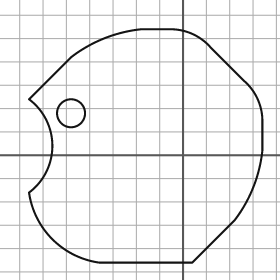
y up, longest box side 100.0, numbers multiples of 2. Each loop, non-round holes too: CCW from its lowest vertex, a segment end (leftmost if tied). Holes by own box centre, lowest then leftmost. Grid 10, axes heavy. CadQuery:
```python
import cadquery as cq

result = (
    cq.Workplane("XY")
    .moveTo(-36.0, -46.0)
    .lineTo(4.0, -46.0)
    .lineTo(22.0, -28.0)
    .threePointArc((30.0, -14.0), (34.0, 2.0))
    .lineTo(34.0, 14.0)
    .threePointArc((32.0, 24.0), (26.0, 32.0))
    .lineTo(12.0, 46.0)
    .threePointArc((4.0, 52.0), (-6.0, 54.0))
    .lineTo(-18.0, 54.0)
    .threePointArc((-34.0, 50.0), (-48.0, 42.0))
    .lineTo(-66.0, 24.0)
    .threePointArc((-56.0, 4.0), (-66.0, -16.0))
    .threePointArc((-56.0, -36.0), (-36.0, -46.0))
    .close()
    .moveTo(-48.0, 18.0)
    .circle(6.0)
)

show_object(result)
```